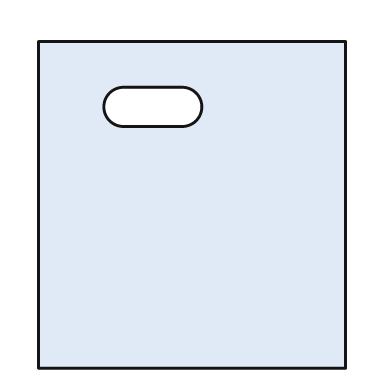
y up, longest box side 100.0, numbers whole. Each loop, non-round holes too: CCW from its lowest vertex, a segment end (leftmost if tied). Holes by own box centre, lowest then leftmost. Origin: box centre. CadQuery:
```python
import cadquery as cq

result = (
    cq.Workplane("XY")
    .moveTo(-47.0, -50.0)
    .lineTo(47.0, -50.0)
    .lineTo(47.0, 50.0)
    .lineTo(-47.0, 50.0)
    .close()
    .moveTo(-21.0, 24.0)
    .lineTo(-3.0, 24.0)
    .threePointArc((3.0, 30.0), (-3.0, 36.0))
    .lineTo(-21.0, 36.0)
    .threePointArc((-27.0, 30.0), (-21.0, 24.0))
    .close()
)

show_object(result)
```